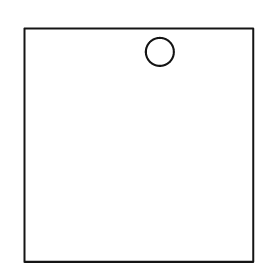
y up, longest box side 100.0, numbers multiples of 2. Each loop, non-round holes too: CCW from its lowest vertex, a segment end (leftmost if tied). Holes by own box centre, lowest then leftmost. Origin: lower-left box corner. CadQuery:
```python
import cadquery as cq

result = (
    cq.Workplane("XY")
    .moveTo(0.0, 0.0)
    .lineTo(98.0, 0.0)
    .lineTo(98.0, 100.0)
    .lineTo(0.0, 100.0)
    .close()
    .moveTo(58.0, 90.0)
    .circle(6.0)
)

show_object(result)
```